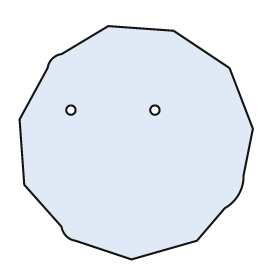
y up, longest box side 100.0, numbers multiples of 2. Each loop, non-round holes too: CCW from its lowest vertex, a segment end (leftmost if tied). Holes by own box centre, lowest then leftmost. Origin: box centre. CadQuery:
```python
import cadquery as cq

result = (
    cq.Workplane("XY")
    .moveTo(-2.0, -50.0)
    .lineTo(26.0, -42.0)
    .lineTo(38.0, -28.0)
    .threePointArc((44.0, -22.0), (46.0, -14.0))
    .lineTo(50.0, 6.0)
    .lineTo(40.0, 32.0)
    .lineTo(16.0, 48.0)
    .lineTo(-12.0, 50.0)
    .lineTo(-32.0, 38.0)
    .threePointArc((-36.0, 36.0), (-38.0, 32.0))
    .lineTo(-50.0, 10.0)
    .lineTo(-48.0, -18.0)
    .lineTo(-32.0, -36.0)
    .threePointArc((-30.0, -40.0), (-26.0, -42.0))
    .close()
    .moveTo(-28.0, 14.0)
    .circle(2.0)
    .moveTo(8.0, 14.0)
    .circle(2.0)
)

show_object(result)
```